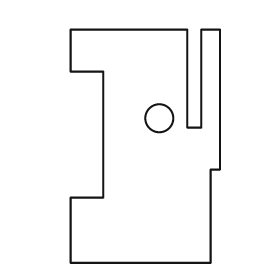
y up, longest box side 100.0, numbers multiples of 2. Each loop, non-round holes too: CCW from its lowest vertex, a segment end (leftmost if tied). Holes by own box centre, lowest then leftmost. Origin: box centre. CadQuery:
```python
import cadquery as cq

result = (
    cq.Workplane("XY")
    .moveTo(-32.0, -50.0)
    .lineTo(28.0, -50.0)
    .lineTo(28.0, -10.0)
    .lineTo(32.0, -10.0)
    .lineTo(32.0, 50.0)
    .lineTo(24.0, 50.0)
    .lineTo(24.0, 8.0)
    .lineTo(18.0, 8.0)
    .lineTo(18.0, 50.0)
    .lineTo(-32.0, 50.0)
    .lineTo(-32.0, 32.0)
    .lineTo(-18.0, 32.0)
    .lineTo(-18.0, -22.0)
    .lineTo(-32.0, -22.0)
    .close()
    .moveTo(6.0, 12.0)
    .circle(6.0)
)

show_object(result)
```